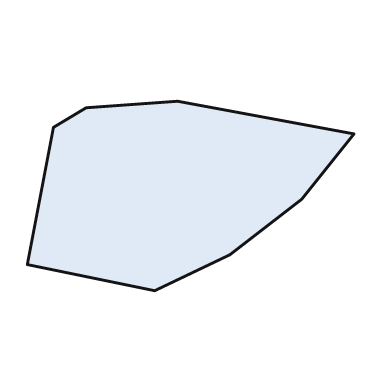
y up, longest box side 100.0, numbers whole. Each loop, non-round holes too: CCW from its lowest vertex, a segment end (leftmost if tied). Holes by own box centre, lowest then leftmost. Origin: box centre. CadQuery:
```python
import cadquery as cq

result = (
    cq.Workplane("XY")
    .moveTo(-11.0, -29.0)
    .lineTo(12.0, -18.0)
    .lineTo(34.0, -1.0)
    .lineTo(50.0, 19.0)
    .lineTo(-4.0, 29.0)
    .lineTo(-32.0, 27.0)
    .lineTo(-42.0, 21.0)
    .lineTo(-50.0, -21.0)
    .close()
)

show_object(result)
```